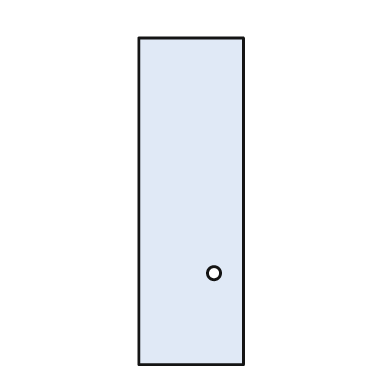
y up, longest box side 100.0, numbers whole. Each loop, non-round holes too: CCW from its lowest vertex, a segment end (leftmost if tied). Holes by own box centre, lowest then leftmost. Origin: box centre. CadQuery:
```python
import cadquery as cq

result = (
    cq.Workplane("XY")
    .moveTo(-16.0, -50.0)
    .lineTo(16.0, -50.0)
    .lineTo(16.0, 50.0)
    .lineTo(-16.0, 50.0)
    .close()
    .moveTo(7.0, -22.0)
    .circle(2.0)
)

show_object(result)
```